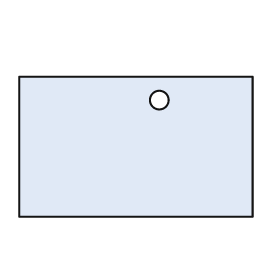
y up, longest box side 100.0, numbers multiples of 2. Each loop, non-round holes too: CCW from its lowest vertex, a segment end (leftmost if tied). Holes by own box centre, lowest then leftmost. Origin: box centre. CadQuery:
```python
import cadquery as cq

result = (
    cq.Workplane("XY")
    .moveTo(-50.0, -30.0)
    .lineTo(50.0, -30.0)
    .lineTo(50.0, 30.0)
    .lineTo(-50.0, 30.0)
    .close()
    .moveTo(10.0, 20.0)
    .circle(4.0)
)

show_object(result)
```